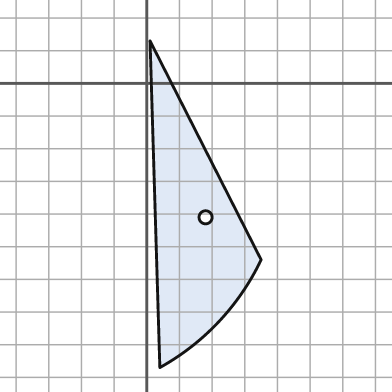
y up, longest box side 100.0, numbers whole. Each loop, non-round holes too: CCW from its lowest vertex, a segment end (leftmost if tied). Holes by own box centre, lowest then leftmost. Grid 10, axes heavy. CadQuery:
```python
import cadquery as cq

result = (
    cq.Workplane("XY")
    .moveTo(4.0, -87.0)
    .threePointArc((22.0, -73.0), (35.0, -54.0))
    .lineTo(1.0, 13.0)
    .close()
    .moveTo(18.0, -41.0)
    .circle(2.0)
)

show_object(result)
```